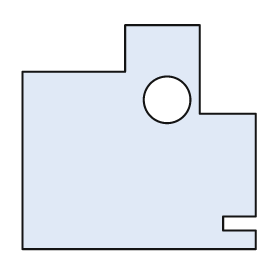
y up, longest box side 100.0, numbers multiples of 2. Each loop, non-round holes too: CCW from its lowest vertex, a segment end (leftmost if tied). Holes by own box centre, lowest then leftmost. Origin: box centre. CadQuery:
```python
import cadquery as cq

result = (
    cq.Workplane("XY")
    .moveTo(-50.0, -48.0)
    .lineTo(50.0, -48.0)
    .lineTo(50.0, -40.0)
    .lineTo(36.0, -40.0)
    .lineTo(36.0, -34.0)
    .lineTo(50.0, -34.0)
    .lineTo(50.0, 10.0)
    .lineTo(26.0, 10.0)
    .lineTo(26.0, 48.0)
    .lineTo(-6.0, 48.0)
    .lineTo(-6.0, 28.0)
    .lineTo(-50.0, 28.0)
    .close()
    .moveTo(12.0, 16.0)
    .circle(10.0)
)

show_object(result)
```